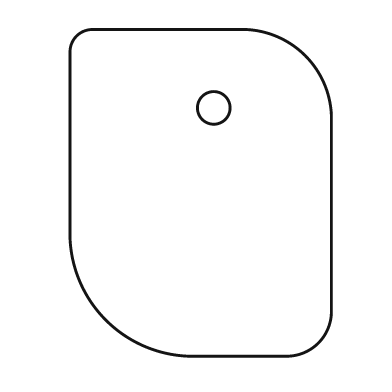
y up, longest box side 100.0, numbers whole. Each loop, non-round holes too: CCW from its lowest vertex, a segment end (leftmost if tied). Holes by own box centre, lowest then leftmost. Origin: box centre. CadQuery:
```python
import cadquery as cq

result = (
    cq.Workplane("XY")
    .moveTo(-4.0, -50.0)
    .lineTo(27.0, -50.0)
    .threePointArc((36.0, -46.0), (40.0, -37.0))
    .lineTo(40.0, 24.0)
    .threePointArc((32.0, 42.0), (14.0, 50.0))
    .lineTo(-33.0, 50.0)
    .threePointArc((-38.0, 48.0), (-40.0, 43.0))
    .lineTo(-40.0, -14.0)
    .threePointArc((-29.0, -39.0), (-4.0, -50.0))
    .close()
    .moveTo(4.0, 26.0)
    .circle(5.0)
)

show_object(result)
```